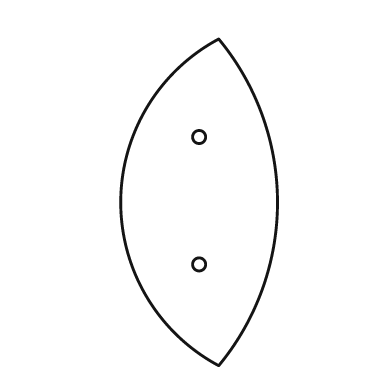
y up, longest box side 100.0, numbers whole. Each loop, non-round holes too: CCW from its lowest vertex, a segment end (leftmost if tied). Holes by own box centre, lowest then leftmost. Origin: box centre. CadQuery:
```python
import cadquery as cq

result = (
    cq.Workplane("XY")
    .moveTo(6.0, -50.0)
    .threePointArc((24.0, 0.0), (6.0, 50.0))
    .threePointArc((-24.0, 0.0), (6.0, -50.0))
    .close()
    .moveTo(0.0, -19.0)
    .circle(2.0)
    .moveTo(0.0, 20.0)
    .circle(2.0)
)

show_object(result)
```